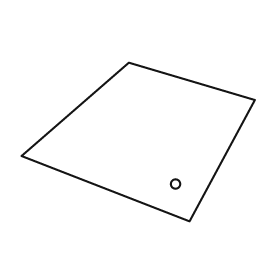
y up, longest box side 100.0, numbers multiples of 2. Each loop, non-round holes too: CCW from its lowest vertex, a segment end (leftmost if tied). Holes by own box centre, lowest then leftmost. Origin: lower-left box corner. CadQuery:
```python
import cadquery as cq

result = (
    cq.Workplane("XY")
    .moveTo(72.0, 0.0)
    .lineTo(100.0, 52.0)
    .lineTo(46.0, 68.0)
    .lineTo(0.0, 28.0)
    .close()
    .moveTo(66.0, 16.0)
    .circle(2.0)
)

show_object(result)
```